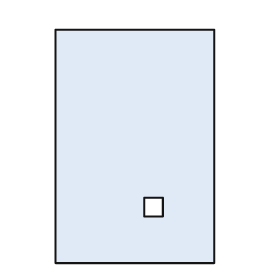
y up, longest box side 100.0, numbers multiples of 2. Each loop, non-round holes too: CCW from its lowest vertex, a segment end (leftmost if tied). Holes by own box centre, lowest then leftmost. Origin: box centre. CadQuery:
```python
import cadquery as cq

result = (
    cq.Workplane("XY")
    .moveTo(-34.0, -50.0)
    .lineTo(34.0, -50.0)
    .lineTo(34.0, 50.0)
    .lineTo(-34.0, 50.0)
    .close()
    .moveTo(4.0, -30.0)
    .lineTo(12.0, -30.0)
    .lineTo(12.0, -22.0)
    .lineTo(4.0, -22.0)
    .close()
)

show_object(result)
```